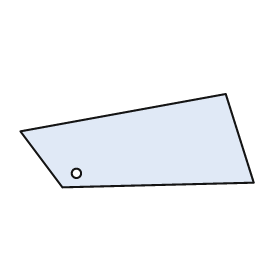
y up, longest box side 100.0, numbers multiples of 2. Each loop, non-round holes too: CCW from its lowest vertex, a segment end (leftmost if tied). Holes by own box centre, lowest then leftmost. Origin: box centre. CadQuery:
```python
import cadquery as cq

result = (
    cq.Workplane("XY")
    .moveTo(-32.0, -20.0)
    .lineTo(50.0, -18.0)
    .lineTo(38.0, 20.0)
    .lineTo(-50.0, 4.0)
    .close()
    .moveTo(-26.0, -14.0)
    .circle(2.0)
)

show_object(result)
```